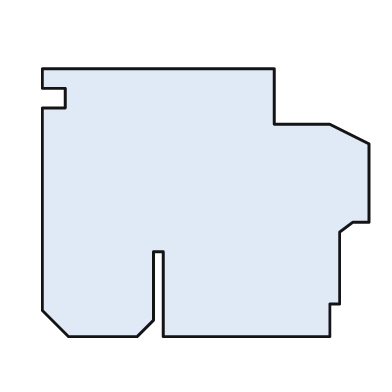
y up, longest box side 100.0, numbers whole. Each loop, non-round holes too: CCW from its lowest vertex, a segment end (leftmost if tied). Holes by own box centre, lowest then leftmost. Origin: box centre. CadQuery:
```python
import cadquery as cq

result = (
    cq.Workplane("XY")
    .moveTo(-42.0, -41.0)
    .lineTo(-21.0, -41.0)
    .lineTo(-16.0, -36.0)
    .lineTo(-16.0, -15.0)
    .lineTo(-13.0, -15.0)
    .lineTo(-13.0, -41.0)
    .lineTo(38.0, -41.0)
    .lineTo(38.0, -31.0)
    .lineTo(41.0, -31.0)
    .lineTo(41.0, -9.0)
    .lineTo(45.0, -6.0)
    .lineTo(50.0, -6.0)
    .lineTo(50.0, 18.0)
    .lineTo(38.0, 24.0)
    .lineTo(21.0, 24.0)
    .lineTo(21.0, 41.0)
    .lineTo(-50.0, 41.0)
    .lineTo(-50.0, 35.0)
    .lineTo(-43.0, 35.0)
    .lineTo(-43.0, 29.0)
    .lineTo(-50.0, 29.0)
    .lineTo(-50.0, -33.0)
    .close()
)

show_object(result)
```